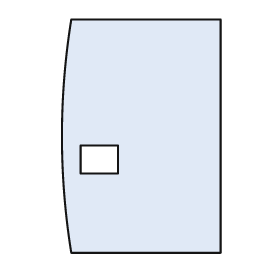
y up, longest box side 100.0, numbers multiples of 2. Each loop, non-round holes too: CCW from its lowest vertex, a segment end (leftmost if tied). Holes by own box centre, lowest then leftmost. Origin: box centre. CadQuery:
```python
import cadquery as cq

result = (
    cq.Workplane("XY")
    .moveTo(-30.0, -50.0)
    .lineTo(34.0, -50.0)
    .lineTo(34.0, 50.0)
    .lineTo(-30.0, 50.0)
    .threePointArc((-34.0, 0.0), (-30.0, -50.0))
    .close()
    .moveTo(-26.0, -16.0)
    .lineTo(-10.0, -16.0)
    .lineTo(-10.0, -4.0)
    .lineTo(-26.0, -4.0)
    .close()
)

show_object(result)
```